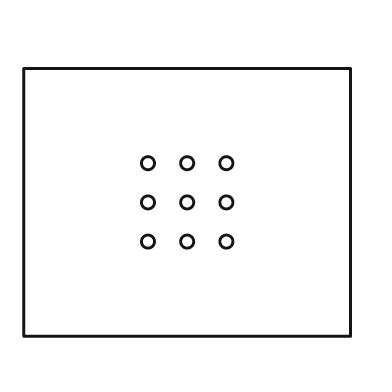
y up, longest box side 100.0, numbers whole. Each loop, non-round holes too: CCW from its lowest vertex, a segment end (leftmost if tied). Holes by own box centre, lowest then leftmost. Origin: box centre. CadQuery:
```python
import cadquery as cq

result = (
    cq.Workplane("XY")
    .moveTo(-50.0, -41.0)
    .lineTo(50.0, -41.0)
    .lineTo(50.0, 41.0)
    .lineTo(-50.0, 41.0)
    .close()
    .moveTo(-12.0, -12.0)
    .circle(2.0)
    .moveTo(0.0, -12.0)
    .circle(2.0)
    .moveTo(12.0, -12.0)
    .circle(2.0)
    .moveTo(-12.0, 0.0)
    .circle(2.0)
    .moveTo(0.0, 0.0)
    .circle(2.0)
    .moveTo(12.0, 0.0)
    .circle(2.0)
    .moveTo(-12.0, 12.0)
    .circle(2.0)
    .moveTo(0.0, 12.0)
    .circle(2.0)
    .moveTo(12.0, 12.0)
    .circle(2.0)
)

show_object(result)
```